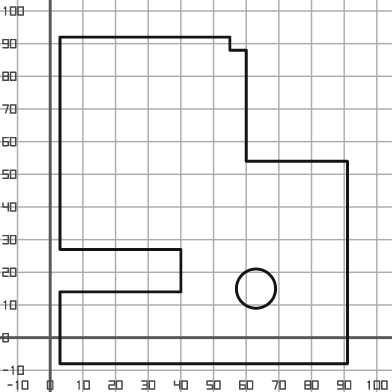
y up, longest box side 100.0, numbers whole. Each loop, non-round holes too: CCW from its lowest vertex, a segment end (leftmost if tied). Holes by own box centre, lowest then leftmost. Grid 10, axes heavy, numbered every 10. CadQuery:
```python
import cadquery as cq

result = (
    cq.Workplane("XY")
    .moveTo(3.0, -8.0)
    .lineTo(91.0, -8.0)
    .lineTo(91.0, 54.0)
    .lineTo(60.0, 54.0)
    .lineTo(60.0, 88.0)
    .lineTo(55.0, 88.0)
    .lineTo(55.0, 92.0)
    .lineTo(3.0, 92.0)
    .lineTo(3.0, 27.0)
    .lineTo(40.0, 27.0)
    .lineTo(40.0, 14.0)
    .lineTo(3.0, 14.0)
    .close()
    .moveTo(63.0, 15.0)
    .circle(6.0)
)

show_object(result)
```